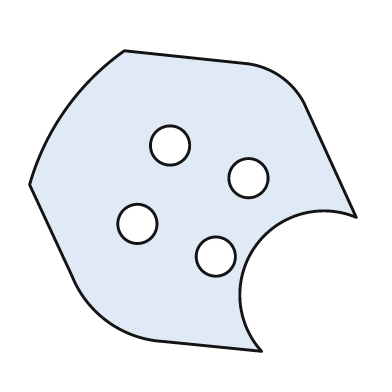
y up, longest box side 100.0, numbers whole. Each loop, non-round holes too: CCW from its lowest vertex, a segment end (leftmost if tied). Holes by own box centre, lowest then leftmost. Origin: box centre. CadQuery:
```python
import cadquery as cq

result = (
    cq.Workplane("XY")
    .moveTo(21.0, -46.0)
    .threePointArc((19.0, -14.0), (50.0, -5.0))
    .lineTo(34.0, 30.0)
    .threePointArc((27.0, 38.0), (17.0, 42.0))
    .lineTo(-21.0, 46.0)
    .threePointArc((-39.0, 28.0), (-50.0, 5.0))
    .lineTo(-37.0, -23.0)
    .threePointArc((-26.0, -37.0), (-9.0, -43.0))
    .close()
    .moveTo(7.0, -17.0)
    .circle(6.0)
    .moveTo(-17.0, -7.0)
    .circle(6.0)
    .moveTo(17.0, 7.0)
    .circle(6.0)
    .moveTo(-7.0, 17.0)
    .circle(6.0)
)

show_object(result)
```